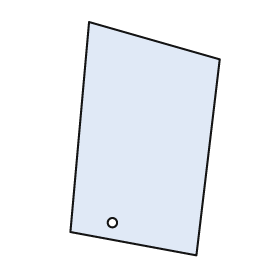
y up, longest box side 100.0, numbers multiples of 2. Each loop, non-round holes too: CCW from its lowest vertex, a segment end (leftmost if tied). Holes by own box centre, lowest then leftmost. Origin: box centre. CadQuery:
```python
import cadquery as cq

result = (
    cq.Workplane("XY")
    .moveTo(22.0, -50.0)
    .lineTo(32.0, 34.0)
    .lineTo(-24.0, 50.0)
    .lineTo(-32.0, -40.0)
    .close()
    .moveTo(-14.0, -36.0)
    .circle(2.0)
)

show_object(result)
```